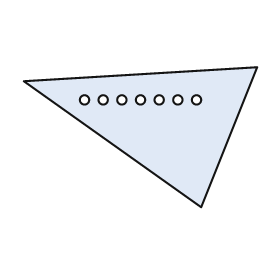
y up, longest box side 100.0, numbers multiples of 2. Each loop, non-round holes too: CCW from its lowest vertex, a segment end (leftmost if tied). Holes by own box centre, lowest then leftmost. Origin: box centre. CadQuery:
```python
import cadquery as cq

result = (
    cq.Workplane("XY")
    .moveTo(26.0, -30.0)
    .lineTo(50.0, 30.0)
    .lineTo(-50.0, 24.0)
    .close()
    .moveTo(-24.0, 16.0)
    .circle(2.0)
    .moveTo(-16.0, 16.0)
    .circle(2.0)
    .moveTo(-8.0, 16.0)
    .circle(2.0)
    .moveTo(0.0, 16.0)
    .circle(2.0)
    .moveTo(8.0, 16.0)
    .circle(2.0)
    .moveTo(16.0, 16.0)
    .circle(2.0)
    .moveTo(24.0, 16.0)
    .circle(2.0)
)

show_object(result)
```